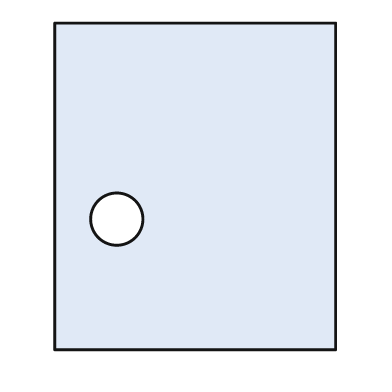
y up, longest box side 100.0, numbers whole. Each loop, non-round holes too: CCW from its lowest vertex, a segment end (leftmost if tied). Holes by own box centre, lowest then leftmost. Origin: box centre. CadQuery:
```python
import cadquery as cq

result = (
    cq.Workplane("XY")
    .moveTo(-43.0, -50.0)
    .lineTo(43.0, -50.0)
    .lineTo(43.0, 50.0)
    .lineTo(-43.0, 50.0)
    .close()
    .moveTo(-24.0, -10.0)
    .circle(8.0)
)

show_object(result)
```